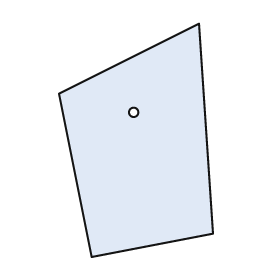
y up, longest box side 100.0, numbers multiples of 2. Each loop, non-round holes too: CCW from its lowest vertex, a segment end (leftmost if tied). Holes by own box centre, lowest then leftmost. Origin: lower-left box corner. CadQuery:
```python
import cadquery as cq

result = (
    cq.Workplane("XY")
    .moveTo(14.0, 0.0)
    .lineTo(66.0, 10.0)
    .lineTo(60.0, 100.0)
    .lineTo(0.0, 70.0)
    .close()
    .moveTo(32.0, 62.0)
    .circle(2.0)
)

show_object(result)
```